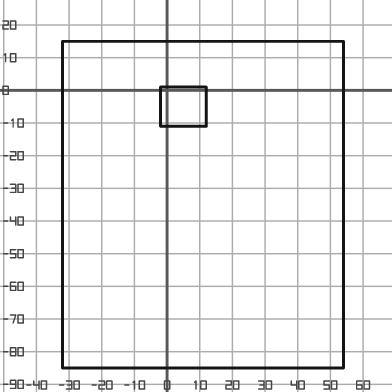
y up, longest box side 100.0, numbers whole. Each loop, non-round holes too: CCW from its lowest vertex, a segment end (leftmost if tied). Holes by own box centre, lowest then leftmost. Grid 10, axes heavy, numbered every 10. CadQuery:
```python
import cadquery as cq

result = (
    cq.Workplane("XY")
    .moveTo(-32.0, -85.0)
    .lineTo(54.0, -85.0)
    .lineTo(54.0, 15.0)
    .lineTo(-32.0, 15.0)
    .close()
    .moveTo(-2.0, -11.0)
    .lineTo(12.0, -11.0)
    .lineTo(12.0, 1.0)
    .lineTo(-2.0, 1.0)
    .close()
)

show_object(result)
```